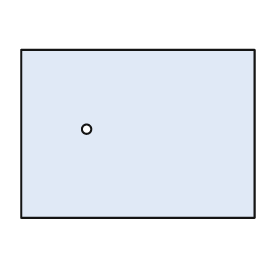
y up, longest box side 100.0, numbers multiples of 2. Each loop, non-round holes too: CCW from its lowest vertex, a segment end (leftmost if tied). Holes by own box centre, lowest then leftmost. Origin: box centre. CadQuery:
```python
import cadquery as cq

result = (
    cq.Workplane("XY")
    .moveTo(-50.0, -36.0)
    .lineTo(50.0, -36.0)
    .lineTo(50.0, 36.0)
    .lineTo(-50.0, 36.0)
    .close()
    .moveTo(-22.0, 2.0)
    .circle(2.0)
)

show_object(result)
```